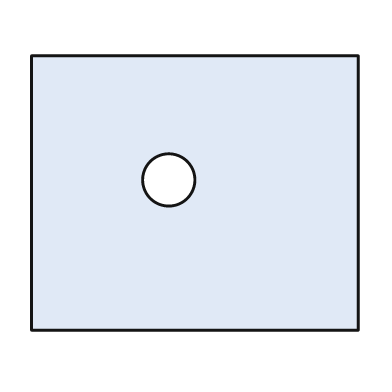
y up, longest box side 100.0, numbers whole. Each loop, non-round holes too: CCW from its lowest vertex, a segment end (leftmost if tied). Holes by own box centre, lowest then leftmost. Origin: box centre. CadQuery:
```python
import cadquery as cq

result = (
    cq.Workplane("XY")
    .moveTo(-50.0, -42.0)
    .lineTo(50.0, -42.0)
    .lineTo(50.0, 42.0)
    .lineTo(-50.0, 42.0)
    .close()
    .moveTo(-8.0, 4.0)
    .circle(8.0)
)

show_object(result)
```